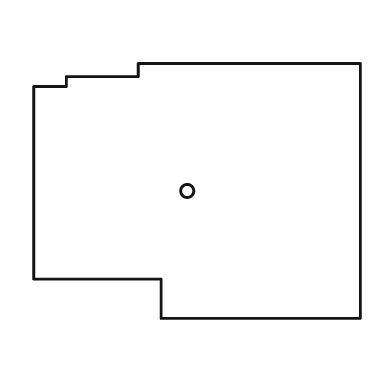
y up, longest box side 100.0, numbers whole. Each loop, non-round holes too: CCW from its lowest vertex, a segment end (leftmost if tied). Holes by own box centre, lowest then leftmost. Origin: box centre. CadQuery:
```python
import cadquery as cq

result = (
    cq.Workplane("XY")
    .moveTo(-11.0, -39.0)
    .lineTo(50.0, -39.0)
    .lineTo(50.0, 39.0)
    .lineTo(-18.0, 39.0)
    .lineTo(-18.0, 35.0)
    .lineTo(-40.0, 35.0)
    .lineTo(-40.0, 32.0)
    .lineTo(-50.0, 32.0)
    .lineTo(-50.0, -27.0)
    .lineTo(-11.0, -27.0)
    .close()
    .moveTo(-3.0, 0.0)
    .circle(2.0)
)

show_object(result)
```